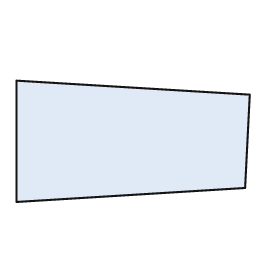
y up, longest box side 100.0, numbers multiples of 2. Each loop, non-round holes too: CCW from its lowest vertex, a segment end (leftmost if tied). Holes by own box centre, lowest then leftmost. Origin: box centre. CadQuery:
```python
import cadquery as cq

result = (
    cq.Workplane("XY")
    .moveTo(-50.0, -26.0)
    .lineTo(48.0, -20.0)
    .lineTo(50.0, 20.0)
    .lineTo(-50.0, 26.0)
    .close()
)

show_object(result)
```